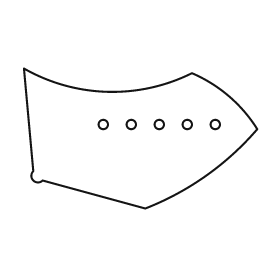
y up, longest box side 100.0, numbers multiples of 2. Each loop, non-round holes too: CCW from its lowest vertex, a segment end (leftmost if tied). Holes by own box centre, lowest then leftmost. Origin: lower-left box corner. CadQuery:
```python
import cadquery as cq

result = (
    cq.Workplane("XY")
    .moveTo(52.0, 0.0)
    .threePointArc((78.0, 14.0), (100.0, 34.0))
    .threePointArc((88.0, 48.0), (72.0, 58.0))
    .threePointArc((36.0, 50.0), (0.0, 60.0))
    .lineTo(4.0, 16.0)
    .threePointArc((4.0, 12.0), (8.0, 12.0))
    .close()
    .moveTo(34.0, 36.0)
    .circle(2.0)
    .moveTo(46.0, 36.0)
    .circle(2.0)
    .moveTo(58.0, 36.0)
    .circle(2.0)
    .moveTo(70.0, 36.0)
    .circle(2.0)
    .moveTo(82.0, 36.0)
    .circle(2.0)
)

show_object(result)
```